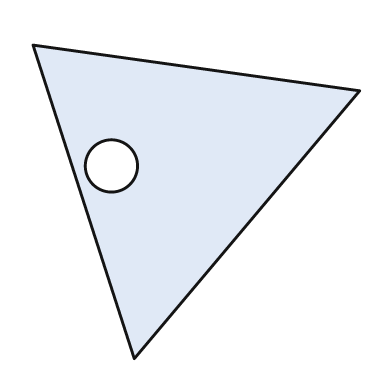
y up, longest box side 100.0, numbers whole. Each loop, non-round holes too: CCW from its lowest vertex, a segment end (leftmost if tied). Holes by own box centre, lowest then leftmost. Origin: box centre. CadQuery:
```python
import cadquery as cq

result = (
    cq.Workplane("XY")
    .moveTo(-19.0, -48.0)
    .lineTo(50.0, 34.0)
    .lineTo(-50.0, 48.0)
    .close()
    .moveTo(-26.0, 11.0)
    .circle(8.0)
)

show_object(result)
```